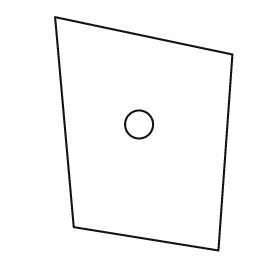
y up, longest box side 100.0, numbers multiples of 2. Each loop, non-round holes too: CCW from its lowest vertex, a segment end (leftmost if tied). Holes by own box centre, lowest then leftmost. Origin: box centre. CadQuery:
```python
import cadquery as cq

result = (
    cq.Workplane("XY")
    .moveTo(32.0, -50.0)
    .lineTo(38.0, 34.0)
    .lineTo(-38.0, 50.0)
    .lineTo(-30.0, -40.0)
    .close()
    .moveTo(-2.0, 4.0)
    .circle(6.0)
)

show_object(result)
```